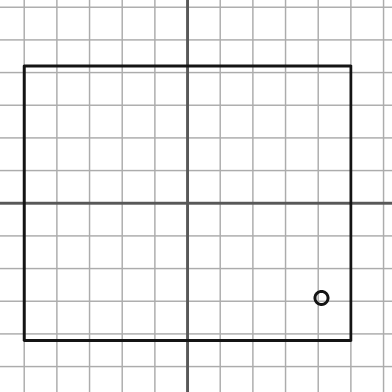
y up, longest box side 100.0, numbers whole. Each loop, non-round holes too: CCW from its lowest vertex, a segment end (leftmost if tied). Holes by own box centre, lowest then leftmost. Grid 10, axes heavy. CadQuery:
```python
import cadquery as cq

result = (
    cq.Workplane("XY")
    .moveTo(-50.0, -42.0)
    .lineTo(50.0, -42.0)
    .lineTo(50.0, 42.0)
    .lineTo(-50.0, 42.0)
    .close()
    .moveTo(41.0, -29.0)
    .circle(2.0)
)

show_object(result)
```